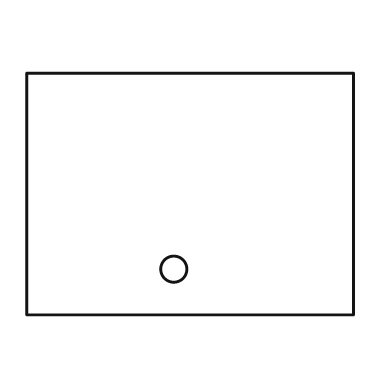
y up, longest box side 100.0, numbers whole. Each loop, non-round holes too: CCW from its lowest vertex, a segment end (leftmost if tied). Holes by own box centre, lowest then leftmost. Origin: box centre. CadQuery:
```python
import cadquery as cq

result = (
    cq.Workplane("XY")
    .moveTo(-50.0, -37.0)
    .lineTo(50.0, -37.0)
    .lineTo(50.0, 37.0)
    .lineTo(-50.0, 37.0)
    .close()
    .moveTo(-5.0, -23.0)
    .circle(4.0)
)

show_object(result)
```